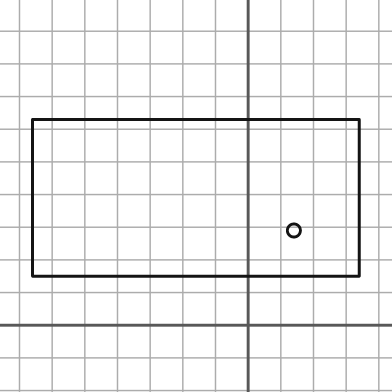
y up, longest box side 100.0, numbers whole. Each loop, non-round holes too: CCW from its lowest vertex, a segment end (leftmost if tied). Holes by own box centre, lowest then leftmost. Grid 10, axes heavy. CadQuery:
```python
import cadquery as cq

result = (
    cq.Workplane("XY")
    .moveTo(-66.0, 15.0)
    .lineTo(34.0, 15.0)
    .lineTo(34.0, 63.0)
    .lineTo(-66.0, 63.0)
    .close()
    .moveTo(14.0, 29.0)
    .circle(2.0)
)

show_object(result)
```